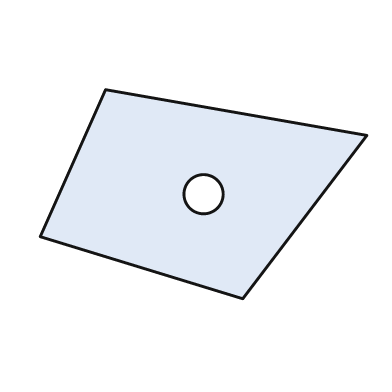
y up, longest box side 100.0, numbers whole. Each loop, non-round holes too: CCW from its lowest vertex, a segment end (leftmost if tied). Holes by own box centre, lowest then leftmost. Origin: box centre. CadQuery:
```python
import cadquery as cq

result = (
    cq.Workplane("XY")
    .moveTo(12.0, -32.0)
    .lineTo(50.0, 18.0)
    .lineTo(-30.0, 32.0)
    .lineTo(-50.0, -13.0)
    .close()
    .moveTo(0.0, 0.0)
    .circle(6.0)
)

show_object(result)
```